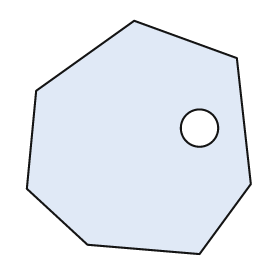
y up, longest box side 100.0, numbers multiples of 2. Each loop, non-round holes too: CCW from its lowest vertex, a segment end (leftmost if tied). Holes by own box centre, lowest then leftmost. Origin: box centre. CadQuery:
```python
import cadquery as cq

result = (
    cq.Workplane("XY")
    .moveTo(26.0, -50.0)
    .lineTo(48.0, -20.0)
    .lineTo(42.0, 34.0)
    .lineTo(-2.0, 50.0)
    .lineTo(-44.0, 20.0)
    .lineTo(-48.0, -22.0)
    .lineTo(-22.0, -46.0)
    .close()
    .moveTo(26.0, 4.0)
    .circle(8.0)
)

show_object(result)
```